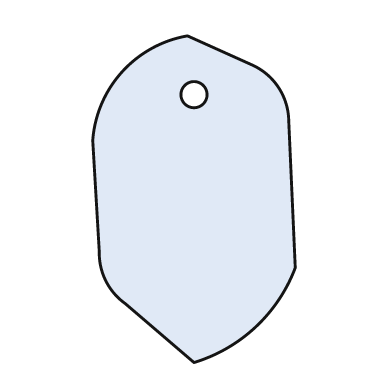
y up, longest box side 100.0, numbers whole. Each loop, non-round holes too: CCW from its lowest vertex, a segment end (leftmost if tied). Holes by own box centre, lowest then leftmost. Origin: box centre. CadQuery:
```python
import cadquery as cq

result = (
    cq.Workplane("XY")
    .moveTo(0.0, -50.0)
    .threePointArc((19.0, -39.0), (31.0, -21.0))
    .lineTo(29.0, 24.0)
    .threePointArc((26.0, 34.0), (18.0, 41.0))
    .lineTo(-2.0, 50.0)
    .threePointArc((-22.0, 39.0), (-31.0, 18.0))
    .lineTo(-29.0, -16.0)
    .threePointArc((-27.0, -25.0), (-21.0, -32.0))
    .close()
    .moveTo(0.0, 32.0)
    .circle(4.0)
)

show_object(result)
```